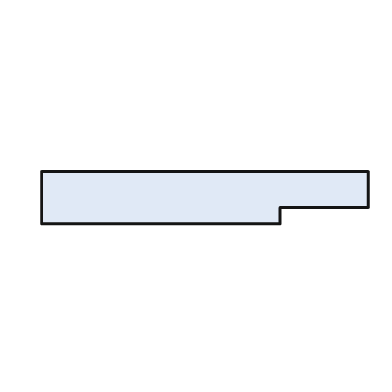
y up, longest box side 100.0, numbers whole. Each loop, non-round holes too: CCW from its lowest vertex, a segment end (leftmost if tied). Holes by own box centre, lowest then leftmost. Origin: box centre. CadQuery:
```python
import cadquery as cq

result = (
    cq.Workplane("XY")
    .moveTo(-50.0, -8.0)
    .lineTo(23.0, -8.0)
    .lineTo(23.0, -3.0)
    .lineTo(50.0, -3.0)
    .lineTo(50.0, 8.0)
    .lineTo(-50.0, 8.0)
    .close()
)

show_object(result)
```